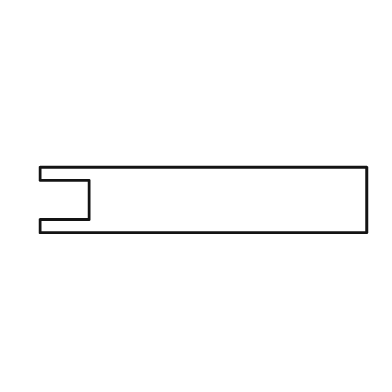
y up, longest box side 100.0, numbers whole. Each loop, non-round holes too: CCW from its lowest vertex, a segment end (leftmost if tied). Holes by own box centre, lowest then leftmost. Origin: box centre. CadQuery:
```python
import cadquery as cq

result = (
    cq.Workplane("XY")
    .moveTo(-50.0, -10.0)
    .lineTo(50.0, -10.0)
    .lineTo(50.0, 10.0)
    .lineTo(-50.0, 10.0)
    .lineTo(-50.0, 6.0)
    .lineTo(-35.0, 6.0)
    .lineTo(-35.0, -6.0)
    .lineTo(-50.0, -6.0)
    .close()
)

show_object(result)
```